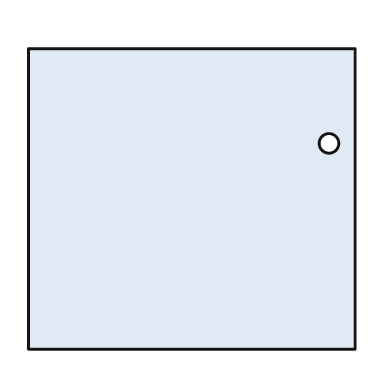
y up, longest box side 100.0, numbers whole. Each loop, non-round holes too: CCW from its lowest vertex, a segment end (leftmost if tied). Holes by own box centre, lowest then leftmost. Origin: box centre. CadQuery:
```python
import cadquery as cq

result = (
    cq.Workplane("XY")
    .moveTo(-50.0, -46.0)
    .lineTo(50.0, -46.0)
    .lineTo(50.0, 46.0)
    .lineTo(-50.0, 46.0)
    .close()
    .moveTo(42.0, 17.0)
    .circle(3.0)
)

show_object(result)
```